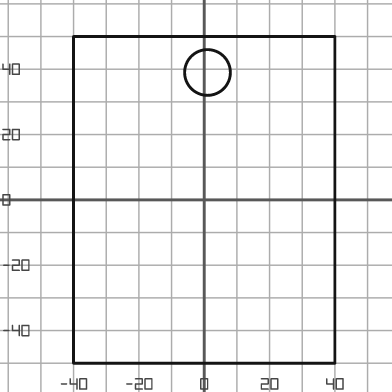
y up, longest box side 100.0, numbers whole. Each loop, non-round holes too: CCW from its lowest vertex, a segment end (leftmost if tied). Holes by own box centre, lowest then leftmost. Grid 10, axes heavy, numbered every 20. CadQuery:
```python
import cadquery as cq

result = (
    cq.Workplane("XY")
    .moveTo(-40.0, -50.0)
    .lineTo(40.0, -50.0)
    .lineTo(40.0, 50.0)
    .lineTo(-40.0, 50.0)
    .close()
    .moveTo(1.0, 39.0)
    .circle(7.0)
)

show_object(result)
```